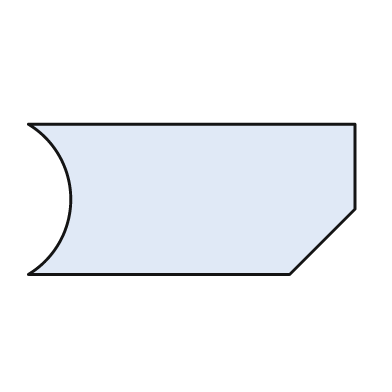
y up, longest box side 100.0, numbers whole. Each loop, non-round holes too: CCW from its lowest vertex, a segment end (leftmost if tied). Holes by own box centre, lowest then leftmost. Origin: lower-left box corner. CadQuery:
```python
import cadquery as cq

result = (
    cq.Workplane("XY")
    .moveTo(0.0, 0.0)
    .lineTo(80.0, 0.0)
    .lineTo(100.0, 20.0)
    .lineTo(100.0, 46.0)
    .lineTo(0.0, 46.0)
    .threePointArc((13.0, 23.0), (0.0, 0.0))
    .close()
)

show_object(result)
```